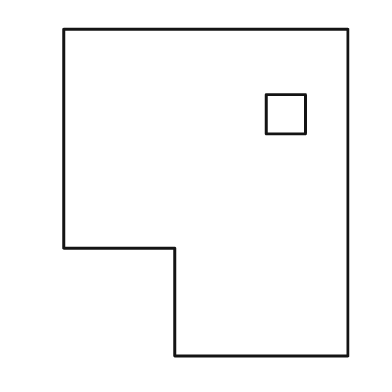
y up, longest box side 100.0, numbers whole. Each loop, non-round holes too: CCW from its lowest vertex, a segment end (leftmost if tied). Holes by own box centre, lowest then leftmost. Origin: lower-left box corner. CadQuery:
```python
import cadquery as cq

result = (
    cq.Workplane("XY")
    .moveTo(34.0, 0.0)
    .lineTo(87.0, 0.0)
    .lineTo(87.0, 100.0)
    .lineTo(0.0, 100.0)
    .lineTo(0.0, 33.0)
    .lineTo(34.0, 33.0)
    .close()
    .moveTo(62.0, 68.0)
    .lineTo(74.0, 68.0)
    .lineTo(74.0, 80.0)
    .lineTo(62.0, 80.0)
    .close()
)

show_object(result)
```